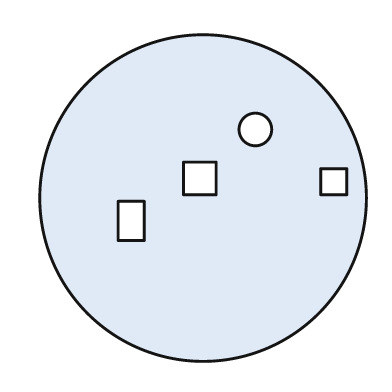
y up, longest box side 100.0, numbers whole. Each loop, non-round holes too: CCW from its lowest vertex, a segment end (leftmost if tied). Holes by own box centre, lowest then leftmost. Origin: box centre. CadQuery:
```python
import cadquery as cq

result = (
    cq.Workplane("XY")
    .moveTo(0.0, 0.0)
    .circle(50.0)
    .moveTo(-26.0, -13.0)
    .lineTo(-18.0, -13.0)
    .lineTo(-18.0, -1.0)
    .lineTo(-26.0, -1.0)
    .close()
    .moveTo(36.0, 1.0)
    .lineTo(44.0, 1.0)
    .lineTo(44.0, 9.0)
    .lineTo(36.0, 9.0)
    .close()
    .moveTo(-6.0, 1.0)
    .lineTo(4.0, 1.0)
    .lineTo(4.0, 11.0)
    .lineTo(-6.0, 11.0)
    .close()
    .moveTo(16.0, 21.0)
    .circle(5.0)
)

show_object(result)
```